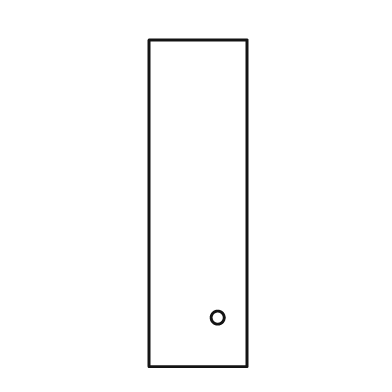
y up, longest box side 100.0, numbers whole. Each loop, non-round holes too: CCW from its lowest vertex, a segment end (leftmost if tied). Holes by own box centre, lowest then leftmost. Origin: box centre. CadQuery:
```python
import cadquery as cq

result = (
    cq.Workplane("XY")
    .moveTo(-15.0, -50.0)
    .lineTo(15.0, -50.0)
    .lineTo(15.0, 50.0)
    .lineTo(-15.0, 50.0)
    .close()
    .moveTo(6.0, -35.0)
    .circle(2.0)
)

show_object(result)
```